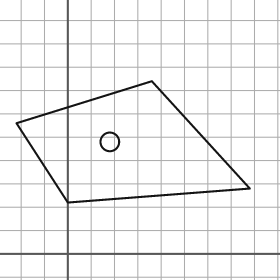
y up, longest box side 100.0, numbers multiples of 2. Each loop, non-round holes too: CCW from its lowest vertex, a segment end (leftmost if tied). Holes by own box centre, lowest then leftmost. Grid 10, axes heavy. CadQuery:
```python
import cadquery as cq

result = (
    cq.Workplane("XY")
    .moveTo(0.0, 22.0)
    .lineTo(78.0, 28.0)
    .lineTo(36.0, 74.0)
    .lineTo(-22.0, 56.0)
    .close()
    .moveTo(18.0, 48.0)
    .circle(4.0)
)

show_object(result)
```